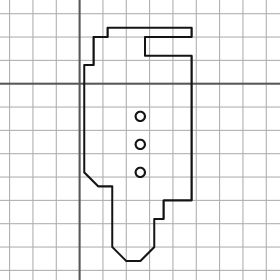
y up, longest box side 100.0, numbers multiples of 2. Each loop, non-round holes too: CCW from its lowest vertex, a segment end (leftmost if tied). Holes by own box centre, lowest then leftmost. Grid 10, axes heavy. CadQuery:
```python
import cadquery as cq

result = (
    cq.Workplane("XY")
    .moveTo(20.0, -76.0)
    .lineTo(26.0, -76.0)
    .lineTo(32.0, -70.0)
    .lineTo(32.0, -58.0)
    .lineTo(36.0, -58.0)
    .lineTo(36.0, -50.0)
    .lineTo(48.0, -50.0)
    .lineTo(48.0, 12.0)
    .lineTo(28.0, 12.0)
    .lineTo(28.0, 20.0)
    .lineTo(48.0, 20.0)
    .lineTo(48.0, 24.0)
    .lineTo(12.0, 24.0)
    .lineTo(12.0, 20.0)
    .lineTo(6.0, 20.0)
    .lineTo(6.0, 8.0)
    .lineTo(2.0, 8.0)
    .lineTo(2.0, -38.0)
    .lineTo(8.0, -44.0)
    .lineTo(14.0, -44.0)
    .lineTo(14.0, -70.0)
    .close()
    .moveTo(26.0, -38.0)
    .circle(2.0)
    .moveTo(26.0, -26.0)
    .circle(2.0)
    .moveTo(26.0, -14.0)
    .circle(2.0)
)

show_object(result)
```